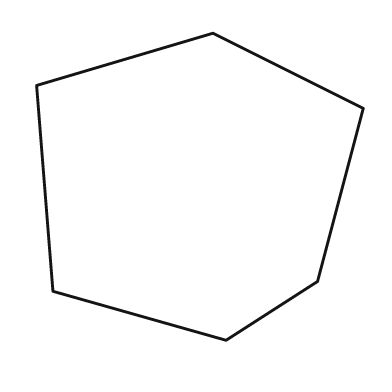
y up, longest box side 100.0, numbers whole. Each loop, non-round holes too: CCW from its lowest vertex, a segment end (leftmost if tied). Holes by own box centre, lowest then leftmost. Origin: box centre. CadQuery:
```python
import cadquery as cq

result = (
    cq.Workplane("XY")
    .moveTo(8.0, -47.0)
    .lineTo(36.0, -29.0)
    .lineTo(50.0, 24.0)
    .lineTo(4.0, 47.0)
    .lineTo(-50.0, 31.0)
    .lineTo(-45.0, -32.0)
    .close()
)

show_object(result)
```